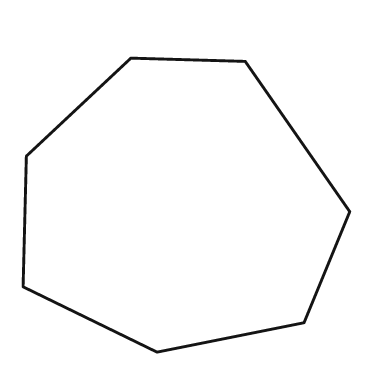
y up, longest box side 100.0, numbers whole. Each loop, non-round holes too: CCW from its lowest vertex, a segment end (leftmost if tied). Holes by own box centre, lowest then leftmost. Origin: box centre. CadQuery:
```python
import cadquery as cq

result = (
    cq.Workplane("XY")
    .moveTo(-9.0, -45.0)
    .lineTo(36.0, -36.0)
    .lineTo(50.0, -2.0)
    .lineTo(18.0, 44.0)
    .lineTo(-17.0, 45.0)
    .lineTo(-49.0, 15.0)
    .lineTo(-50.0, -25.0)
    .close()
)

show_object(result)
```